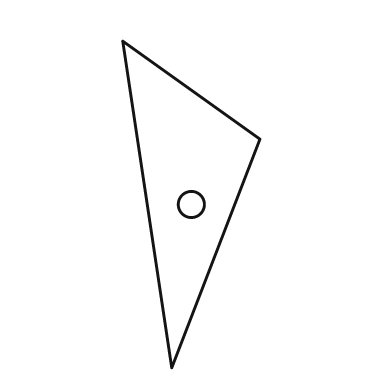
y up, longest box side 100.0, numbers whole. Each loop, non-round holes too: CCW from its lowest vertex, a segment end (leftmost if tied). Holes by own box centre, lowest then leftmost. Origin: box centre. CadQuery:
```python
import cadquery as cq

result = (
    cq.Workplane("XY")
    .moveTo(-6.0, -50.0)
    .lineTo(21.0, 20.0)
    .lineTo(-21.0, 50.0)
    .close()
    .moveTo(0.0, 0.0)
    .circle(4.0)
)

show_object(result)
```